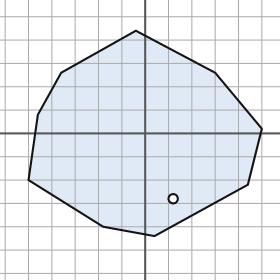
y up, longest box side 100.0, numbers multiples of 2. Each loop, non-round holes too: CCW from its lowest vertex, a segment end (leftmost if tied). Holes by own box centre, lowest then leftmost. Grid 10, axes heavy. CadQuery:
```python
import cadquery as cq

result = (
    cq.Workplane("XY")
    .moveTo(4.0, -44.0)
    .lineTo(44.0, -22.0)
    .lineTo(50.0, 2.0)
    .lineTo(30.0, 26.0)
    .lineTo(-4.0, 44.0)
    .lineTo(-36.0, 26.0)
    .lineTo(-46.0, 8.0)
    .lineTo(-50.0, -20.0)
    .lineTo(-18.0, -40.0)
    .close()
    .moveTo(12.0, -28.0)
    .circle(2.0)
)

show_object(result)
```